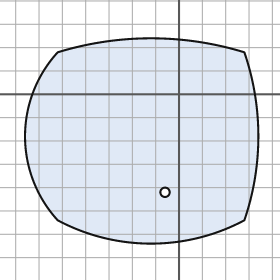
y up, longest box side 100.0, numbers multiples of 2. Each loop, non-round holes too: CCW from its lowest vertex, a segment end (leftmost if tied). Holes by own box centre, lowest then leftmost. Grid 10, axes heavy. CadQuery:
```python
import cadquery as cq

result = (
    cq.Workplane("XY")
    .moveTo(-52.0, -54.0)
    .threePointArc((-12.0, -64.0), (28.0, -54.0))
    .threePointArc((34.0, -18.0), (28.0, 18.0))
    .threePointArc((-12.0, 24.0), (-52.0, 18.0))
    .threePointArc((-66.0, -18.0), (-52.0, -54.0))
    .close()
    .moveTo(-6.0, -42.0)
    .circle(2.0)
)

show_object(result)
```